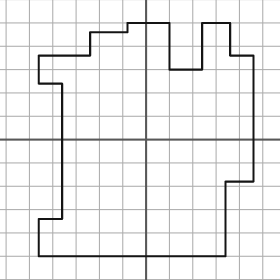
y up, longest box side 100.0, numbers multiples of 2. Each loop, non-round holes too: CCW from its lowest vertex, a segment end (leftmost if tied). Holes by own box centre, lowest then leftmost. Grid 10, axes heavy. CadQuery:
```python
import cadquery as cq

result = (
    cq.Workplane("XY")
    .moveTo(-46.0, -50.0)
    .lineTo(34.0, -50.0)
    .lineTo(34.0, -18.0)
    .lineTo(46.0, -18.0)
    .lineTo(46.0, 36.0)
    .lineTo(36.0, 36.0)
    .lineTo(36.0, 50.0)
    .lineTo(24.0, 50.0)
    .lineTo(24.0, 30.0)
    .lineTo(10.0, 30.0)
    .lineTo(10.0, 50.0)
    .lineTo(-8.0, 50.0)
    .lineTo(-8.0, 46.0)
    .lineTo(-24.0, 46.0)
    .lineTo(-24.0, 36.0)
    .lineTo(-46.0, 36.0)
    .lineTo(-46.0, 24.0)
    .lineTo(-36.0, 24.0)
    .lineTo(-36.0, -34.0)
    .lineTo(-46.0, -34.0)
    .close()
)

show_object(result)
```